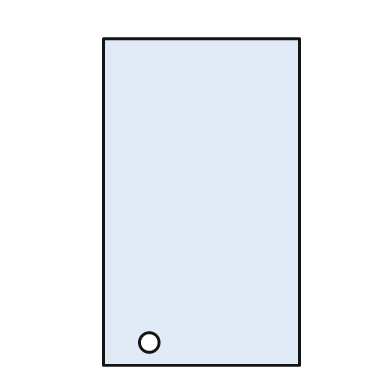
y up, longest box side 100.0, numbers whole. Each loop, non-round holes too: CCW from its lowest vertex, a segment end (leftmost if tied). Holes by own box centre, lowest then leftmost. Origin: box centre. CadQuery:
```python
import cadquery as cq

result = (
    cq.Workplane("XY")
    .moveTo(-30.0, -50.0)
    .lineTo(30.0, -50.0)
    .lineTo(30.0, 50.0)
    .lineTo(-30.0, 50.0)
    .close()
    .moveTo(-16.0, -43.0)
    .circle(3.0)
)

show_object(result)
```